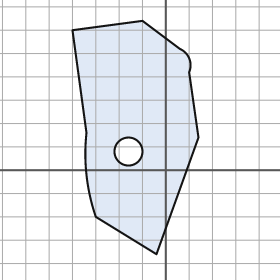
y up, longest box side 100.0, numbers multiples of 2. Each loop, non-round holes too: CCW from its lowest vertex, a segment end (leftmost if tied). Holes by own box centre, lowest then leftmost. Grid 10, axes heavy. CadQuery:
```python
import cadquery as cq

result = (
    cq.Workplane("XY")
    .moveTo(-4.0, -36.0)
    .lineTo(14.0, 14.0)
    .lineTo(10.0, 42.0)
    .threePointArc((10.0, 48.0), (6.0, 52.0))
    .lineTo(-10.0, 64.0)
    .lineTo(-40.0, 60.0)
    .lineTo(-34.0, 16.0)
    .threePointArc((-34.0, -2.0), (-30.0, -20.0))
    .close()
    .moveTo(-16.0, 8.0)
    .circle(6.0)
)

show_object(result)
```